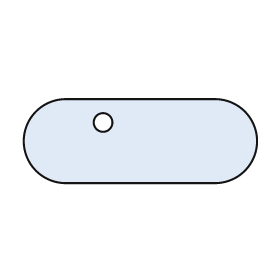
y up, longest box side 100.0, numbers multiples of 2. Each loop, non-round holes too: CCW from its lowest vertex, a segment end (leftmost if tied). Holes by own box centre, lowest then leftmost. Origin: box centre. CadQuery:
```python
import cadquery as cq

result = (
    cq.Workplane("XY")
    .moveTo(-32.0, -18.0)
    .lineTo(32.0, -18.0)
    .threePointArc((50.0, 0.0), (32.0, 18.0))
    .lineTo(-32.0, 18.0)
    .threePointArc((-50.0, 0.0), (-32.0, -18.0))
    .close()
    .moveTo(-16.0, 8.0)
    .circle(4.0)
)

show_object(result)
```